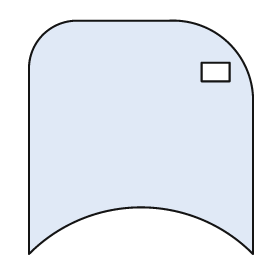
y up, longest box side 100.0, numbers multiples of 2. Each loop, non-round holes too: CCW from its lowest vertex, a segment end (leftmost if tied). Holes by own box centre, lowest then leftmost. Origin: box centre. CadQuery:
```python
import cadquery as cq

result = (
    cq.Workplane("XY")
    .moveTo(-48.0, -50.0)
    .threePointArc((0.0, -30.0), (48.0, -50.0))
    .lineTo(48.0, 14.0)
    .threePointArc((38.0, 40.0), (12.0, 50.0))
    .lineTo(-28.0, 50.0)
    .threePointArc((-42.0, 44.0), (-48.0, 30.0))
    .close()
    .moveTo(26.0, 24.0)
    .lineTo(38.0, 24.0)
    .lineTo(38.0, 32.0)
    .lineTo(26.0, 32.0)
    .close()
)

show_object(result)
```